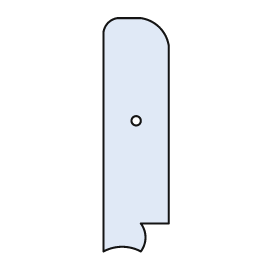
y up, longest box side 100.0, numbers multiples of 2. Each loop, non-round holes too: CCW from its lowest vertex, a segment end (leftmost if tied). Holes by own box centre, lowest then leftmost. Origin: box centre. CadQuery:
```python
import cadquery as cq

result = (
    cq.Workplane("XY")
    .moveTo(-14.0, -50.0)
    .threePointArc((-6.0, -48.0), (2.0, -50.0))
    .threePointArc((4.0, -44.0), (2.0, -38.0))
    .lineTo(14.0, -38.0)
    .lineTo(14.0, 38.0)
    .threePointArc((10.0, 46.0), (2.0, 50.0))
    .lineTo(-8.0, 50.0)
    .threePointArc((-12.0, 48.0), (-14.0, 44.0))
    .close()
    .moveTo(0.0, 6.0)
    .circle(2.0)
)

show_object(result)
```